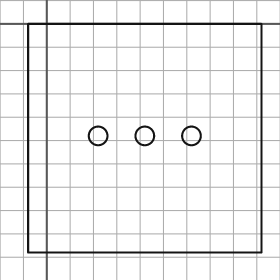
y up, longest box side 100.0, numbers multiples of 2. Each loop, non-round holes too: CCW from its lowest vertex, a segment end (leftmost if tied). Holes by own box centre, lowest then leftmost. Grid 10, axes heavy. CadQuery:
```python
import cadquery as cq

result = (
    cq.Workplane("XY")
    .moveTo(-8.0, -98.0)
    .lineTo(92.0, -98.0)
    .lineTo(92.0, 0.0)
    .lineTo(-8.0, 0.0)
    .close()
    .moveTo(22.0, -48.0)
    .circle(4.0)
    .moveTo(42.0, -48.0)
    .circle(4.0)
    .moveTo(62.0, -48.0)
    .circle(4.0)
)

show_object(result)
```